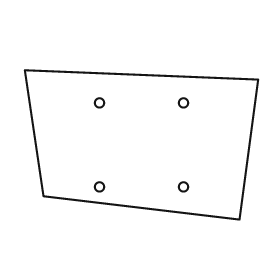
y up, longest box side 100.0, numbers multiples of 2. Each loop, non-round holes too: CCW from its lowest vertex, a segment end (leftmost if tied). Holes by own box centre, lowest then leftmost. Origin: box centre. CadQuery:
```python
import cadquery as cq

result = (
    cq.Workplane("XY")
    .moveTo(42.0, -32.0)
    .lineTo(50.0, 28.0)
    .lineTo(-50.0, 32.0)
    .lineTo(-42.0, -22.0)
    .close()
    .moveTo(-18.0, -18.0)
    .circle(2.0)
    .moveTo(18.0, -18.0)
    .circle(2.0)
    .moveTo(-18.0, 18.0)
    .circle(2.0)
    .moveTo(18.0, 18.0)
    .circle(2.0)
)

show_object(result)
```